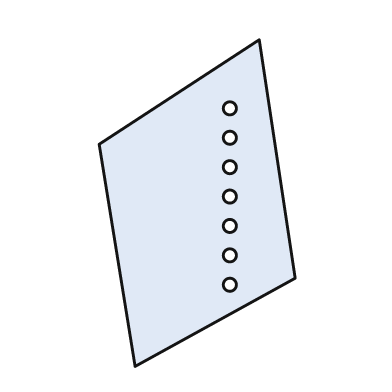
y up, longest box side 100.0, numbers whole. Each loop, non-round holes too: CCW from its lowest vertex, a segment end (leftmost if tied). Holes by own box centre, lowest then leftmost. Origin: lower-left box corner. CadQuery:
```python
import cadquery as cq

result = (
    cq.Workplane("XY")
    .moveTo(11.0, 0.0)
    .lineTo(60.0, 27.0)
    .lineTo(49.0, 100.0)
    .lineTo(0.0, 68.0)
    .close()
    .moveTo(40.0, 25.0)
    .circle(2.0)
    .moveTo(40.0, 34.0)
    .circle(2.0)
    .moveTo(40.0, 43.0)
    .circle(2.0)
    .moveTo(40.0, 52.0)
    .circle(2.0)
    .moveTo(40.0, 61.0)
    .circle(2.0)
    .moveTo(40.0, 70.0)
    .circle(2.0)
    .moveTo(40.0, 79.0)
    .circle(2.0)
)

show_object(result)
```